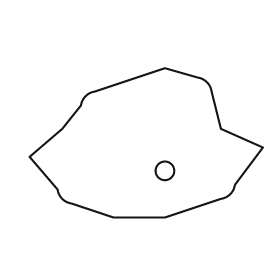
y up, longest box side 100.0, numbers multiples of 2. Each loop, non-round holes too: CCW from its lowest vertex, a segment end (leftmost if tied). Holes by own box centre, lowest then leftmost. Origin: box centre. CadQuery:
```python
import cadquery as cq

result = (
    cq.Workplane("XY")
    .moveTo(-14.0, -32.0)
    .lineTo(8.0, -32.0)
    .lineTo(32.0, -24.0)
    .threePointArc((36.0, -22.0), (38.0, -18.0))
    .lineTo(50.0, -2.0)
    .lineTo(32.0, 6.0)
    .lineTo(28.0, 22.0)
    .threePointArc((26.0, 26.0), (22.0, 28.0))
    .lineTo(8.0, 32.0)
    .lineTo(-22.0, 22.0)
    .threePointArc((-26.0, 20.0), (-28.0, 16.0))
    .lineTo(-36.0, 6.0)
    .lineTo(-50.0, -6.0)
    .lineTo(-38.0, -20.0)
    .threePointArc((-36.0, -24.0), (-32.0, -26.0))
    .close()
    .moveTo(8.0, -12.0)
    .circle(4.0)
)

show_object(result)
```